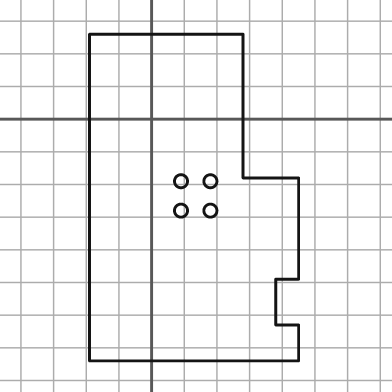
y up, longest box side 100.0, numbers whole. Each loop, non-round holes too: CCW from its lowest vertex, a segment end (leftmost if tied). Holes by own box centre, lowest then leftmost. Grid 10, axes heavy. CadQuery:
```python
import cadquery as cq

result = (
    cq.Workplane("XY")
    .moveTo(-19.0, -74.0)
    .lineTo(45.0, -74.0)
    .lineTo(45.0, -63.0)
    .lineTo(38.0, -63.0)
    .lineTo(38.0, -49.0)
    .lineTo(45.0, -49.0)
    .lineTo(45.0, -18.0)
    .lineTo(28.0, -18.0)
    .lineTo(28.0, 26.0)
    .lineTo(-19.0, 26.0)
    .close()
    .moveTo(9.0, -28.0)
    .circle(2.0)
    .moveTo(18.0, -28.0)
    .circle(2.0)
    .moveTo(9.0, -19.0)
    .circle(2.0)
    .moveTo(18.0, -19.0)
    .circle(2.0)
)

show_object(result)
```